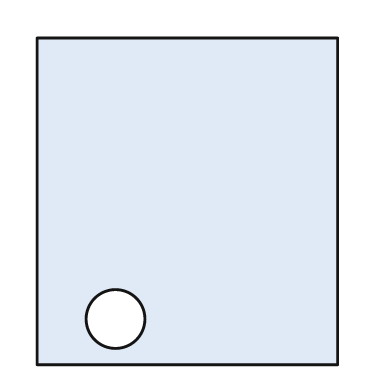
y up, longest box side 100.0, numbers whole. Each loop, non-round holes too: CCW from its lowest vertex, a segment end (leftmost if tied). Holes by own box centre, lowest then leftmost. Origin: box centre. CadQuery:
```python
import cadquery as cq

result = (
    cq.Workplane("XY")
    .moveTo(-46.0, -50.0)
    .lineTo(46.0, -50.0)
    .lineTo(46.0, 50.0)
    .lineTo(-46.0, 50.0)
    .close()
    .moveTo(-22.0, -36.0)
    .circle(9.0)
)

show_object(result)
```